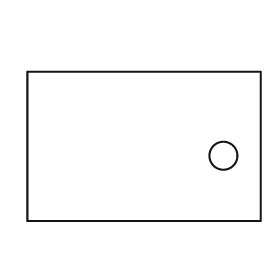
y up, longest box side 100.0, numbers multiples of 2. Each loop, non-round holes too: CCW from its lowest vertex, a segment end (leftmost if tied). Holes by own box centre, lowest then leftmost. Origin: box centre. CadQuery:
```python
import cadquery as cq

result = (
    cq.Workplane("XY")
    .moveTo(-50.0, -32.0)
    .lineTo(50.0, -32.0)
    .lineTo(50.0, 32.0)
    .lineTo(-50.0, 32.0)
    .close()
    .moveTo(34.0, -4.0)
    .circle(6.0)
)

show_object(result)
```